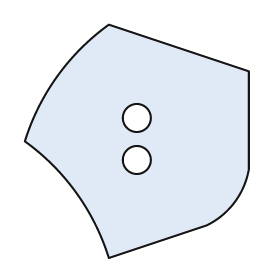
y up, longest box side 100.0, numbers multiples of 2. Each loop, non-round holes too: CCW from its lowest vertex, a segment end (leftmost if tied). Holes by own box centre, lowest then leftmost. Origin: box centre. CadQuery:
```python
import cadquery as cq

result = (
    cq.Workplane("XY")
    .moveTo(-12.0, -50.0)
    .lineTo(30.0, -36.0)
    .threePointArc((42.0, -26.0), (48.0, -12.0))
    .lineTo(48.0, 30.0)
    .lineTo(-12.0, 50.0)
    .threePointArc((-34.0, 28.0), (-48.0, 0.0))
    .threePointArc((-26.0, -22.0), (-12.0, -50.0))
    .close()
    .moveTo(0.0, -8.0)
    .circle(6.0)
    .moveTo(0.0, 10.0)
    .circle(6.0)
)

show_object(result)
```